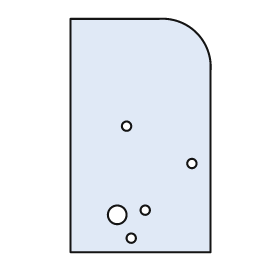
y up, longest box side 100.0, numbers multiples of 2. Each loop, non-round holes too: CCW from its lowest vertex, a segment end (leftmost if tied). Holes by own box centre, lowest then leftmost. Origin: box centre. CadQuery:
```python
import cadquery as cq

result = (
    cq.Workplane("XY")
    .moveTo(-30.0, -50.0)
    .lineTo(30.0, -50.0)
    .lineTo(30.0, 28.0)
    .threePointArc((24.0, 44.0), (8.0, 50.0))
    .lineTo(-30.0, 50.0)
    .close()
    .moveTo(-4.0, -44.0)
    .circle(2.0)
    .moveTo(-10.0, -34.0)
    .circle(4.0)
    .moveTo(2.0, -32.0)
    .circle(2.0)
    .moveTo(22.0, -12.0)
    .circle(2.0)
    .moveTo(-6.0, 4.0)
    .circle(2.0)
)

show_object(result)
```